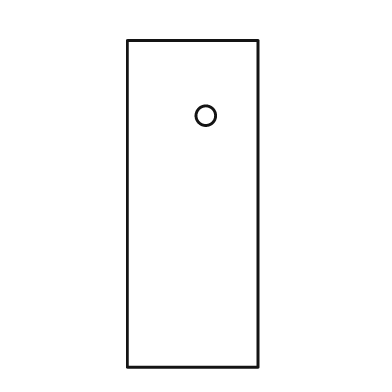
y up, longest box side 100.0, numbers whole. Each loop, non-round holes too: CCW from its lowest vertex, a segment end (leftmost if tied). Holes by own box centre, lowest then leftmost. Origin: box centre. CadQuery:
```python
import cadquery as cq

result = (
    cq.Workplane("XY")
    .moveTo(-20.0, -50.0)
    .lineTo(20.0, -50.0)
    .lineTo(20.0, 50.0)
    .lineTo(-20.0, 50.0)
    .close()
    .moveTo(4.0, 27.0)
    .circle(3.0)
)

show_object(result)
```